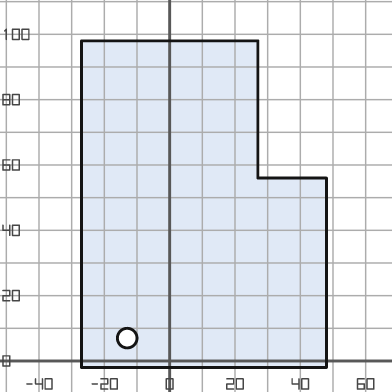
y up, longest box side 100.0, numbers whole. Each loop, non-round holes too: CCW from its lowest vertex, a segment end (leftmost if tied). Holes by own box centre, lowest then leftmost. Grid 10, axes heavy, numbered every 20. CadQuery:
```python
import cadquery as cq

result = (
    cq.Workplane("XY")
    .moveTo(-27.0, -2.0)
    .lineTo(48.0, -2.0)
    .lineTo(48.0, 56.0)
    .lineTo(27.0, 56.0)
    .lineTo(27.0, 98.0)
    .lineTo(-27.0, 98.0)
    .close()
    .moveTo(-13.0, 7.0)
    .circle(3.0)
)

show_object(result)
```